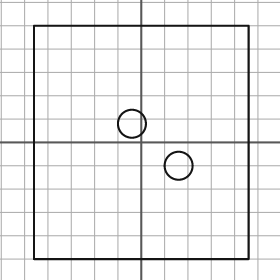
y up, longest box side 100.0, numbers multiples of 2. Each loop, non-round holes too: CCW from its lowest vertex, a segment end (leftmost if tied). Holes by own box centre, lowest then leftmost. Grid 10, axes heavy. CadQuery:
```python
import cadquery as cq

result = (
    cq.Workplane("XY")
    .moveTo(-46.0, -50.0)
    .lineTo(46.0, -50.0)
    .lineTo(46.0, 50.0)
    .lineTo(-46.0, 50.0)
    .close()
    .moveTo(16.0, -10.0)
    .circle(6.0)
    .moveTo(-4.0, 8.0)
    .circle(6.0)
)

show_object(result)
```